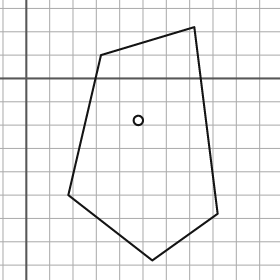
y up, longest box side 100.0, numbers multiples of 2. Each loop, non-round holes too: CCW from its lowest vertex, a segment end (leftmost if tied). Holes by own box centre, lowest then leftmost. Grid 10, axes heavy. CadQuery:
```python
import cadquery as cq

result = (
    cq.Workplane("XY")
    .moveTo(54.0, -78.0)
    .lineTo(82.0, -58.0)
    .lineTo(72.0, 22.0)
    .lineTo(32.0, 10.0)
    .lineTo(18.0, -50.0)
    .close()
    .moveTo(48.0, -18.0)
    .circle(2.0)
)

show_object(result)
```